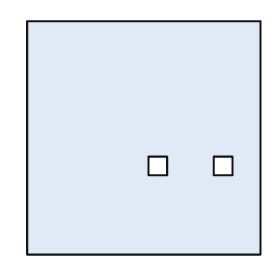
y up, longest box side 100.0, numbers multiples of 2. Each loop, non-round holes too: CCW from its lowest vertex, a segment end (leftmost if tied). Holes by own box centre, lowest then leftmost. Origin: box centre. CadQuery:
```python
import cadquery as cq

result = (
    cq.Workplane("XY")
    .moveTo(-50.0, -50.0)
    .lineTo(50.0, -50.0)
    .lineTo(50.0, 50.0)
    .lineTo(-50.0, 50.0)
    .close()
    .moveTo(2.0, -16.0)
    .lineTo(10.0, -16.0)
    .lineTo(10.0, -8.0)
    .lineTo(2.0, -8.0)
    .close()
    .moveTo(30.0, -16.0)
    .lineTo(38.0, -16.0)
    .lineTo(38.0, -8.0)
    .lineTo(30.0, -8.0)
    .close()
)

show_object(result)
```